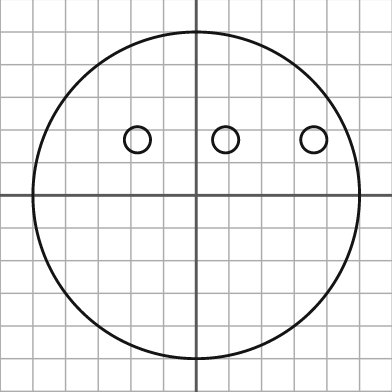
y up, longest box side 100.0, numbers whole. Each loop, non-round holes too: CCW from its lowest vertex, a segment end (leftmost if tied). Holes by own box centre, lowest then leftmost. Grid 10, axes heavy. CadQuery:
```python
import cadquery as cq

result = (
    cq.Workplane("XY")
    .moveTo(0.0, 0.0)
    .circle(50.0)
    .moveTo(-18.0, 17.0)
    .circle(4.0)
    .moveTo(9.0, 17.0)
    .circle(4.0)
    .moveTo(36.0, 17.0)
    .circle(4.0)
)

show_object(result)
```